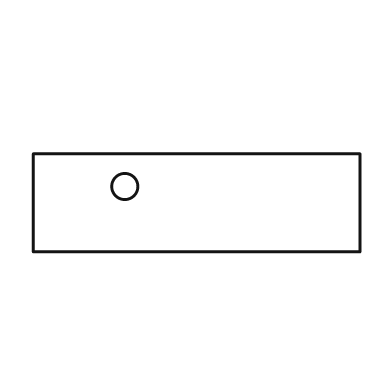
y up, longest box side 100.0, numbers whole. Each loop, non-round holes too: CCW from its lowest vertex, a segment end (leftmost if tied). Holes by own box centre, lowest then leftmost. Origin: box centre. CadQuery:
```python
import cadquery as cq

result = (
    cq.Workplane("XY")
    .moveTo(-50.0, -15.0)
    .lineTo(50.0, -15.0)
    .lineTo(50.0, 15.0)
    .lineTo(-50.0, 15.0)
    .close()
    .moveTo(-22.0, 5.0)
    .circle(4.0)
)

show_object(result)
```